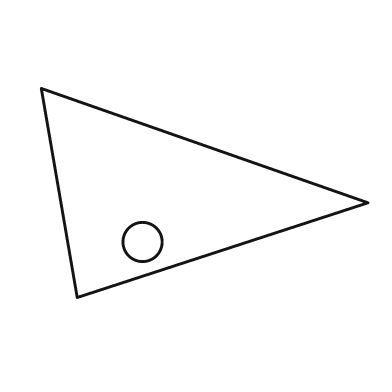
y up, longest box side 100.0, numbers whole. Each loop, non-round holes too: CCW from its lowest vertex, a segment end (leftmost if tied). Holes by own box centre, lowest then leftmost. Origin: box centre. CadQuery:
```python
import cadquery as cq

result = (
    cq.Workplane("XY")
    .moveTo(-39.0, -32.0)
    .lineTo(50.0, -3.0)
    .lineTo(-50.0, 32.0)
    .close()
    .moveTo(-19.0, -15.0)
    .circle(6.0)
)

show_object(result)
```